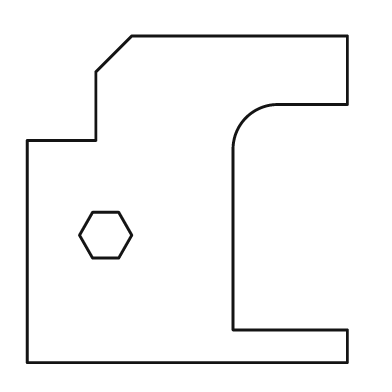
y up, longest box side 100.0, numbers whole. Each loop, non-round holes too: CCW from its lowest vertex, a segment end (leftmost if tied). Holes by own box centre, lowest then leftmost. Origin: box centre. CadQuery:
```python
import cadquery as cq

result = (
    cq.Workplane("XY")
    .moveTo(-49.0, -50.0)
    .lineTo(49.0, -50.0)
    .lineTo(49.0, -40.0)
    .lineTo(14.0, -40.0)
    .lineTo(14.0, 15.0)
    .threePointArc((18.0, 25.0), (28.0, 29.0))
    .lineTo(49.0, 29.0)
    .lineTo(49.0, 50.0)
    .lineTo(-17.0, 50.0)
    .lineTo(-28.0, 39.0)
    .lineTo(-28.0, 18.0)
    .lineTo(-49.0, 18.0)
    .close()
    .moveTo(-29.0, -18.0)
    .lineTo(-21.0, -18.0)
    .lineTo(-17.0, -11.0)
    .lineTo(-21.0, -4.0)
    .lineTo(-29.0, -4.0)
    .lineTo(-33.0, -11.0)
    .close()
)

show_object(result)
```